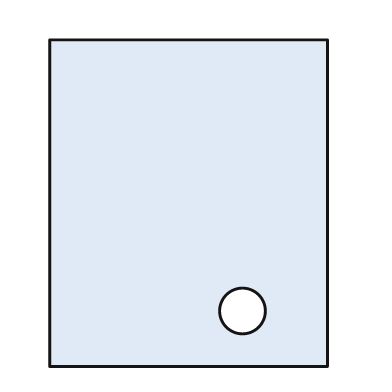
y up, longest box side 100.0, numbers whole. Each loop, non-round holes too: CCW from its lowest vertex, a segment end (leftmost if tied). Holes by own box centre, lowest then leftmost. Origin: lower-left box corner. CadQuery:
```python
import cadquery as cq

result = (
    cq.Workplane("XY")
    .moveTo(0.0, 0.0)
    .lineTo(85.0, 0.0)
    .lineTo(85.0, 100.0)
    .lineTo(0.0, 100.0)
    .close()
    .moveTo(59.0, 17.0)
    .circle(7.0)
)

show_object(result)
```